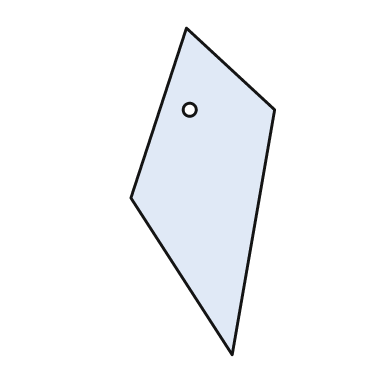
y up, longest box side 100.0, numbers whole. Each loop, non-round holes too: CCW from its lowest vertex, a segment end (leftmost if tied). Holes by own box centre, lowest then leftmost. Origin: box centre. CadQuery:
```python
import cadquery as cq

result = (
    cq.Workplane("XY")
    .moveTo(9.0, -50.0)
    .lineTo(22.0, 25.0)
    .lineTo(-5.0, 50.0)
    .lineTo(-22.0, -2.0)
    .close()
    .moveTo(-4.0, 25.0)
    .circle(2.0)
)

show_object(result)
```